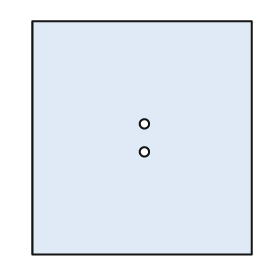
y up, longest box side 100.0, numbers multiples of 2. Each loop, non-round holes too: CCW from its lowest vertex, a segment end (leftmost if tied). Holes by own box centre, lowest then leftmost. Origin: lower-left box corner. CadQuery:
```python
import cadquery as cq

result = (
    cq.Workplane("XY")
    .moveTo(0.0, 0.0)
    .lineTo(94.0, 0.0)
    .lineTo(94.0, 100.0)
    .lineTo(0.0, 100.0)
    .close()
    .moveTo(48.0, 44.0)
    .circle(2.0)
    .moveTo(48.0, 56.0)
    .circle(2.0)
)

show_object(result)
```